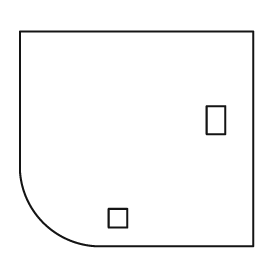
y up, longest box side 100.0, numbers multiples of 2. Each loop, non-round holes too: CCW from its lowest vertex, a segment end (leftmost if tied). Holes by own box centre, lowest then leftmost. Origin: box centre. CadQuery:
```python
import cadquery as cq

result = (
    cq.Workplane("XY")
    .moveTo(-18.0, -46.0)
    .lineTo(50.0, -46.0)
    .lineTo(50.0, 46.0)
    .lineTo(-50.0, 46.0)
    .lineTo(-50.0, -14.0)
    .threePointArc((-40.0, -36.0), (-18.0, -46.0))
    .close()
    .moveTo(-12.0, -38.0)
    .lineTo(-4.0, -38.0)
    .lineTo(-4.0, -30.0)
    .lineTo(-12.0, -30.0)
    .close()
    .moveTo(30.0, 2.0)
    .lineTo(38.0, 2.0)
    .lineTo(38.0, 14.0)
    .lineTo(30.0, 14.0)
    .close()
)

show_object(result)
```